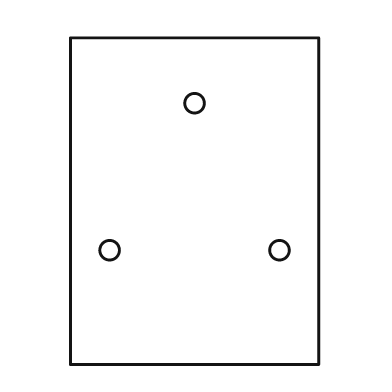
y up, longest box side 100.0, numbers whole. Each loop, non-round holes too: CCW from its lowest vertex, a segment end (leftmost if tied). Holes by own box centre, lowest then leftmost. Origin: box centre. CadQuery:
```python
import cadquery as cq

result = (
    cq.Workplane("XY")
    .moveTo(-38.0, -50.0)
    .lineTo(38.0, -50.0)
    .lineTo(38.0, 50.0)
    .lineTo(-38.0, 50.0)
    .close()
    .moveTo(-26.0, -15.0)
    .circle(3.0)
    .moveTo(26.0, -15.0)
    .circle(3.0)
    .moveTo(0.0, 30.0)
    .circle(3.0)
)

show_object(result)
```